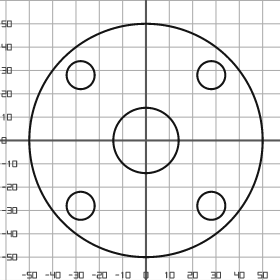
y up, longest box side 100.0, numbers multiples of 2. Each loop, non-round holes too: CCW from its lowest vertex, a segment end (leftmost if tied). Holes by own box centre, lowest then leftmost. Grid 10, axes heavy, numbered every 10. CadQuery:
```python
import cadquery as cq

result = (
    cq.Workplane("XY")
    .moveTo(0.0, 0.0)
    .circle(50.0)
    .moveTo(-28.0, -28.0)
    .circle(6.0)
    .moveTo(28.0, -28.0)
    .circle(6.0)
    .moveTo(0.0, 0.0)
    .circle(14.0)
    .moveTo(-28.0, 28.0)
    .circle(6.0)
    .moveTo(28.0, 28.0)
    .circle(6.0)
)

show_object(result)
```